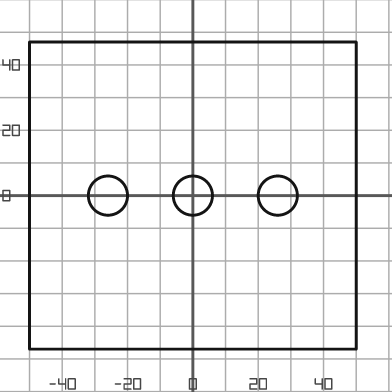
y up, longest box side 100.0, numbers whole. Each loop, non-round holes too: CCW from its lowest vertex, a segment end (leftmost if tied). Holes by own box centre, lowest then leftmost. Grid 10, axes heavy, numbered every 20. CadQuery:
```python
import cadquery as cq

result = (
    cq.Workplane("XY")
    .moveTo(-50.0, -47.0)
    .lineTo(50.0, -47.0)
    .lineTo(50.0, 47.0)
    .lineTo(-50.0, 47.0)
    .close()
    .moveTo(-26.0, 0.0)
    .circle(6.0)
    .moveTo(0.0, 0.0)
    .circle(6.0)
    .moveTo(26.0, 0.0)
    .circle(6.0)
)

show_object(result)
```